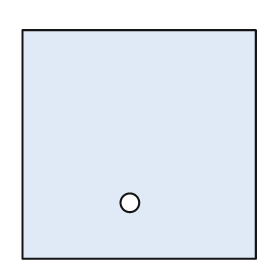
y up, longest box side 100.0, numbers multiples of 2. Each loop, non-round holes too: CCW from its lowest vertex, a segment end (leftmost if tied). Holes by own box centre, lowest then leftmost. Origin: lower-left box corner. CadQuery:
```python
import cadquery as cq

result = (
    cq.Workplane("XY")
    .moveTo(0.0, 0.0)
    .lineTo(100.0, 0.0)
    .lineTo(100.0, 98.0)
    .lineTo(0.0, 98.0)
    .close()
    .moveTo(46.0, 24.0)
    .circle(4.0)
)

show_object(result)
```